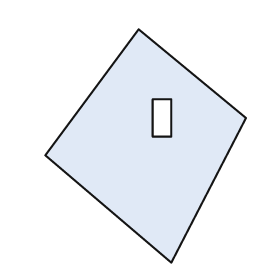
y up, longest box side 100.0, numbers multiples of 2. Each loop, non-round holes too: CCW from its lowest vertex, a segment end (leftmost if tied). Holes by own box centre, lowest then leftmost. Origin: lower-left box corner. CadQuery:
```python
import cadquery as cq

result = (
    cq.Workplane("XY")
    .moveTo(54.0, 0.0)
    .lineTo(86.0, 62.0)
    .lineTo(40.0, 100.0)
    .lineTo(0.0, 46.0)
    .close()
    .moveTo(46.0, 54.0)
    .lineTo(54.0, 54.0)
    .lineTo(54.0, 70.0)
    .lineTo(46.0, 70.0)
    .close()
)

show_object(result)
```